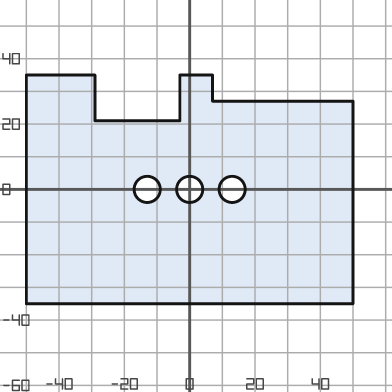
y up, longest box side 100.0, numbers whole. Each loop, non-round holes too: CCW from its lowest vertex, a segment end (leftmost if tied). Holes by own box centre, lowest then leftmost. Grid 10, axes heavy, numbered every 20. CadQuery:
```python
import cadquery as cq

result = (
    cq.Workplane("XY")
    .moveTo(-50.0, -35.0)
    .lineTo(50.0, -35.0)
    .lineTo(50.0, 27.0)
    .lineTo(7.0, 27.0)
    .lineTo(7.0, 35.0)
    .lineTo(-3.0, 35.0)
    .lineTo(-3.0, 21.0)
    .lineTo(-29.0, 21.0)
    .lineTo(-29.0, 35.0)
    .lineTo(-50.0, 35.0)
    .close()
    .moveTo(-13.0, 0.0)
    .circle(4.0)
    .moveTo(0.0, 0.0)
    .circle(4.0)
    .moveTo(13.0, 0.0)
    .circle(4.0)
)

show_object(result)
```